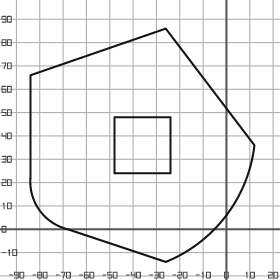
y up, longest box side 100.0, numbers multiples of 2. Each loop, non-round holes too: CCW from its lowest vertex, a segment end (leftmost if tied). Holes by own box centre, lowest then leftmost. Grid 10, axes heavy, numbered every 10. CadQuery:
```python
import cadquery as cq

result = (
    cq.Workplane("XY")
    .moveTo(-26.0, -14.0)
    .threePointArc((0.0, 6.0), (12.0, 36.0))
    .lineTo(-26.0, 86.0)
    .lineTo(-84.0, 66.0)
    .lineTo(-84.0, 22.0)
    .threePointArc((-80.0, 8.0), (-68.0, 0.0))
    .close()
    .moveTo(-48.0, 24.0)
    .lineTo(-24.0, 24.0)
    .lineTo(-24.0, 48.0)
    .lineTo(-48.0, 48.0)
    .close()
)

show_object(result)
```